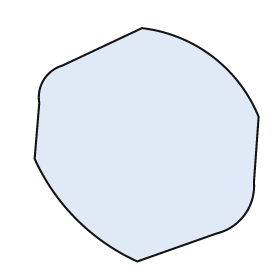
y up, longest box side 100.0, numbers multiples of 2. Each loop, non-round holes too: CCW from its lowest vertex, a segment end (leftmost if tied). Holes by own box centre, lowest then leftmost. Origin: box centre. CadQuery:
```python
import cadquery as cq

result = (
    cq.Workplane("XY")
    .moveTo(-4.0, -50.0)
    .lineTo(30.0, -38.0)
    .threePointArc((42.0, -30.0), (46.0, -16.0))
    .lineTo(48.0, 12.0)
    .threePointArc((28.0, 38.0), (-2.0, 50.0))
    .lineTo(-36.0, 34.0)
    .threePointArc((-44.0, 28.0), (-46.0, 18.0))
    .lineTo(-48.0, -6.0)
    .threePointArc((-30.0, -32.0), (-4.0, -50.0))
    .close()
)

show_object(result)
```